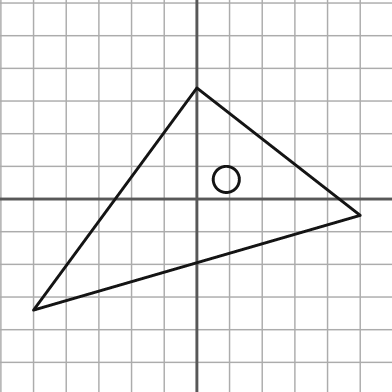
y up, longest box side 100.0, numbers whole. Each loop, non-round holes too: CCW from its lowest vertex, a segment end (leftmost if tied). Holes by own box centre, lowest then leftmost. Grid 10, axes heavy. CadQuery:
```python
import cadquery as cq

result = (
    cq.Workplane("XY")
    .moveTo(-50.0, -34.0)
    .lineTo(50.0, -5.0)
    .lineTo(0.0, 34.0)
    .close()
    .moveTo(9.0, 6.0)
    .circle(4.0)
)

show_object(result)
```